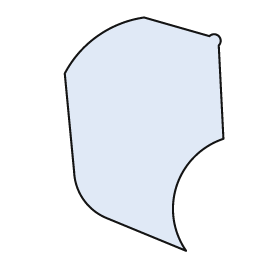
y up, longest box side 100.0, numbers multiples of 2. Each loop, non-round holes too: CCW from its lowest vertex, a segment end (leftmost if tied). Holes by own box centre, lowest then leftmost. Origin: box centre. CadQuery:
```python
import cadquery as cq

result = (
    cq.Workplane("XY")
    .moveTo(18.0, -50.0)
    .threePointArc((14.0, -22.0), (34.0, -2.0))
    .lineTo(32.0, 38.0)
    .threePointArc((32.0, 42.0), (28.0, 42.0))
    .lineTo(0.0, 50.0)
    .threePointArc((-20.0, 42.0), (-34.0, 26.0))
    .lineTo(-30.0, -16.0)
    .threePointArc((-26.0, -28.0), (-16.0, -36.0))
    .close()
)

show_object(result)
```